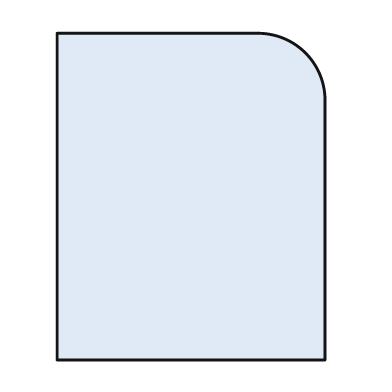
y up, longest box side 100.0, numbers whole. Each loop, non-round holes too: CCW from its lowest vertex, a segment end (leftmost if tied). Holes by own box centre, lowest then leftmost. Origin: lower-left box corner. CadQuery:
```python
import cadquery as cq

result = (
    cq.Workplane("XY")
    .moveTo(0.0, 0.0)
    .lineTo(82.0, 0.0)
    .lineTo(82.0, 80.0)
    .threePointArc((76.0, 94.0), (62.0, 100.0))
    .lineTo(0.0, 100.0)
    .close()
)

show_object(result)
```